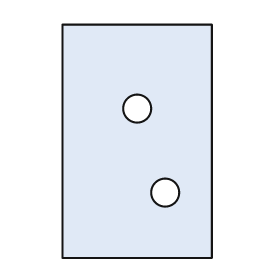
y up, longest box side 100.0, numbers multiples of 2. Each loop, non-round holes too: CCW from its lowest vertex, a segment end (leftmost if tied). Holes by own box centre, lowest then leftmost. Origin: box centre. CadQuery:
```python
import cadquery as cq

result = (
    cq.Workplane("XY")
    .moveTo(-32.0, -50.0)
    .lineTo(32.0, -50.0)
    .lineTo(32.0, 50.0)
    .lineTo(-32.0, 50.0)
    .close()
    .moveTo(12.0, -22.0)
    .circle(6.0)
    .moveTo(0.0, 14.0)
    .circle(6.0)
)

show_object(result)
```